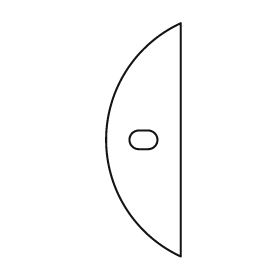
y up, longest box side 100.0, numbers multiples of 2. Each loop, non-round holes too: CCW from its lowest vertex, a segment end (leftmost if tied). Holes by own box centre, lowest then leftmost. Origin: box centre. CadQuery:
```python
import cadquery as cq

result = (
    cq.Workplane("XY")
    .moveTo(16.0, -50.0)
    .lineTo(16.0, 50.0)
    .threePointArc((-16.0, 0.0), (16.0, -50.0))
    .close()
    .moveTo(-2.0, -4.0)
    .lineTo(2.0, -4.0)
    .threePointArc((6.0, 0.0), (2.0, 4.0))
    .lineTo(-2.0, 4.0)
    .threePointArc((-6.0, 0.0), (-2.0, -4.0))
    .close()
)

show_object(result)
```